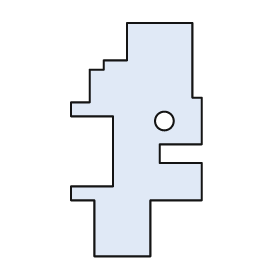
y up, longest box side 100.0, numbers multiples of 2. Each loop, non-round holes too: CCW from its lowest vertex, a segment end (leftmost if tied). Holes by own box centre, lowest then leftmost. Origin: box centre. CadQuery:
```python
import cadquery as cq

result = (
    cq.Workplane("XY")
    .moveTo(-18.0, -50.0)
    .lineTo(6.0, -50.0)
    .lineTo(6.0, -26.0)
    .lineTo(28.0, -26.0)
    .lineTo(28.0, -10.0)
    .lineTo(10.0, -10.0)
    .lineTo(10.0, -2.0)
    .lineTo(28.0, -2.0)
    .lineTo(28.0, 18.0)
    .lineTo(24.0, 18.0)
    .lineTo(24.0, 50.0)
    .lineTo(-4.0, 50.0)
    .lineTo(-4.0, 34.0)
    .lineTo(-14.0, 34.0)
    .lineTo(-14.0, 30.0)
    .lineTo(-20.0, 30.0)
    .lineTo(-20.0, 16.0)
    .lineTo(-28.0, 16.0)
    .lineTo(-28.0, 10.0)
    .lineTo(-10.0, 10.0)
    .lineTo(-10.0, -20.0)
    .lineTo(-28.0, -20.0)
    .lineTo(-28.0, -26.0)
    .lineTo(-18.0, -26.0)
    .close()
    .moveTo(12.0, 8.0)
    .circle(4.0)
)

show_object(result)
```